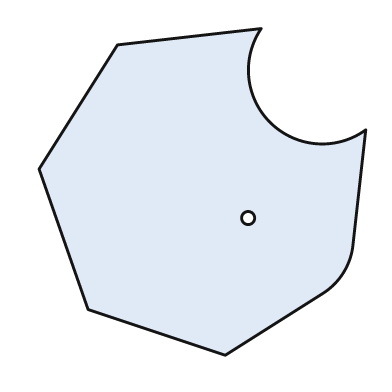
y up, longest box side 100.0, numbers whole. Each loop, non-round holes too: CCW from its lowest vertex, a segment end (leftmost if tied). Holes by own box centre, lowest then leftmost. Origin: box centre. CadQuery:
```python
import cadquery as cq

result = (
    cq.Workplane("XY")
    .moveTo(7.0, -50.0)
    .lineTo(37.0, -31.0)
    .threePointArc((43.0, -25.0), (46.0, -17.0))
    .lineTo(50.0, 19.0)
    .threePointArc((21.0, 21.0), (18.0, 50.0))
    .lineTo(-26.0, 45.0)
    .lineTo(-50.0, 7.0)
    .lineTo(-35.0, -36.0)
    .close()
    .moveTo(14.0, -8.0)
    .circle(2.0)
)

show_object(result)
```